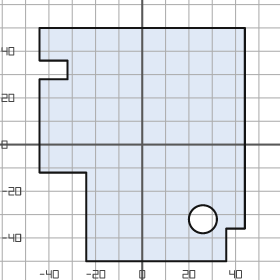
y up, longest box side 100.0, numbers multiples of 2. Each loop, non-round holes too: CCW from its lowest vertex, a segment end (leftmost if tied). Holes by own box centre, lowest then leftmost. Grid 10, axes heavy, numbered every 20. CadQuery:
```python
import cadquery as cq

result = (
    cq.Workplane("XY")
    .moveTo(-24.0, -50.0)
    .lineTo(36.0, -50.0)
    .lineTo(36.0, -36.0)
    .lineTo(44.0, -36.0)
    .lineTo(44.0, 50.0)
    .lineTo(-44.0, 50.0)
    .lineTo(-44.0, 36.0)
    .lineTo(-32.0, 36.0)
    .lineTo(-32.0, 28.0)
    .lineTo(-44.0, 28.0)
    .lineTo(-44.0, -12.0)
    .lineTo(-24.0, -12.0)
    .close()
    .moveTo(26.0, -32.0)
    .circle(6.0)
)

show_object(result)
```